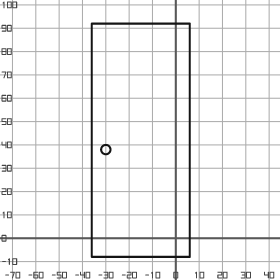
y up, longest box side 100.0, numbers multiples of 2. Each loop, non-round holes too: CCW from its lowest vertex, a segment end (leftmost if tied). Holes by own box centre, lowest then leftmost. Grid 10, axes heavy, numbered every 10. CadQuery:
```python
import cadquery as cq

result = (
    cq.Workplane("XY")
    .moveTo(-36.0, -8.0)
    .lineTo(6.0, -8.0)
    .lineTo(6.0, 92.0)
    .lineTo(-36.0, 92.0)
    .close()
    .moveTo(-30.0, 38.0)
    .circle(2.0)
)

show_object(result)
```